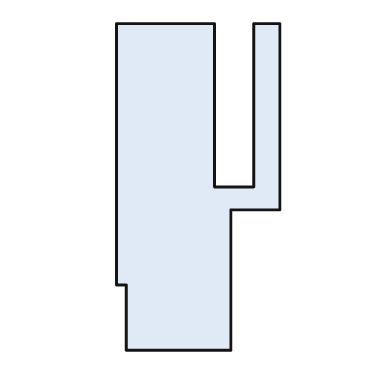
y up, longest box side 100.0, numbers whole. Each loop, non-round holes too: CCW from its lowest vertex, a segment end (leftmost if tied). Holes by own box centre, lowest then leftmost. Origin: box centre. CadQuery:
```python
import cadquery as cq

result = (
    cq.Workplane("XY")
    .moveTo(-22.0, -50.0)
    .lineTo(10.0, -50.0)
    .lineTo(10.0, -7.0)
    .lineTo(25.0, -7.0)
    .lineTo(25.0, 50.0)
    .lineTo(17.0, 50.0)
    .lineTo(17.0, 0.0)
    .lineTo(5.0, 0.0)
    .lineTo(5.0, 50.0)
    .lineTo(-25.0, 50.0)
    .lineTo(-25.0, -30.0)
    .lineTo(-22.0, -30.0)
    .close()
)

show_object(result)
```